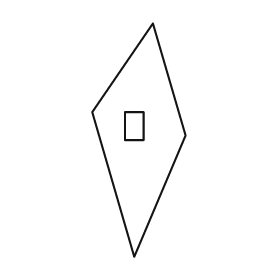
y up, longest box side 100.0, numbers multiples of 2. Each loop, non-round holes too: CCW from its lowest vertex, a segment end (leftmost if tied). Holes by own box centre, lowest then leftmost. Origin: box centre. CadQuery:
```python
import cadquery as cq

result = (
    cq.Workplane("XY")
    .moveTo(-2.0, -50.0)
    .lineTo(20.0, 2.0)
    .lineTo(6.0, 50.0)
    .lineTo(-20.0, 12.0)
    .close()
    .moveTo(-6.0, 0.0)
    .lineTo(2.0, 0.0)
    .lineTo(2.0, 12.0)
    .lineTo(-6.0, 12.0)
    .close()
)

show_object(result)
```